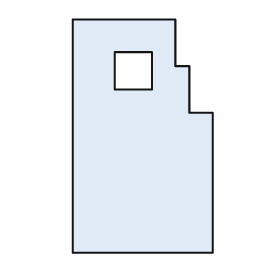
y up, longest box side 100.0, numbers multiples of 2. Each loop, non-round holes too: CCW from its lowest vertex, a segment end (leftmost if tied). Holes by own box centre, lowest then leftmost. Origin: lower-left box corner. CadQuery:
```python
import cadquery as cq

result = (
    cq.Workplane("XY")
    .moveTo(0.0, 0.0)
    .lineTo(60.0, 0.0)
    .lineTo(60.0, 60.0)
    .lineTo(50.0, 60.0)
    .lineTo(50.0, 80.0)
    .lineTo(44.0, 80.0)
    .lineTo(44.0, 100.0)
    .lineTo(0.0, 100.0)
    .close()
    .moveTo(18.0, 70.0)
    .lineTo(34.0, 70.0)
    .lineTo(34.0, 86.0)
    .lineTo(18.0, 86.0)
    .close()
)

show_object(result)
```